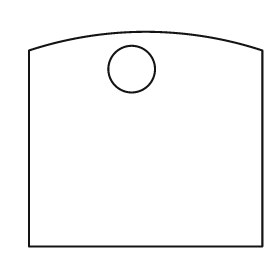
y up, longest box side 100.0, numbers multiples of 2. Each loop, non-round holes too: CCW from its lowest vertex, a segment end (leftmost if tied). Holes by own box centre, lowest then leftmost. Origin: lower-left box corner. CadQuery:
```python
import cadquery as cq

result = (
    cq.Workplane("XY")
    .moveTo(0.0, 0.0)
    .lineTo(100.0, 0.0)
    .lineTo(100.0, 84.0)
    .threePointArc((50.0, 92.0), (0.0, 84.0))
    .close()
    .moveTo(44.0, 76.0)
    .circle(10.0)
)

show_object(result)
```